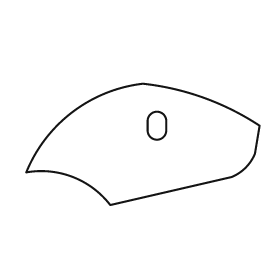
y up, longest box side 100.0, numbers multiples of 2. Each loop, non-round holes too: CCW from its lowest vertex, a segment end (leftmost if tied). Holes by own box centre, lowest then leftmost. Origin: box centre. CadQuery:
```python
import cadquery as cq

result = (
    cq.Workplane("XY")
    .moveTo(-14.0, -26.0)
    .lineTo(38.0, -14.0)
    .threePointArc((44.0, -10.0), (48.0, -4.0))
    .lineTo(50.0, 8.0)
    .threePointArc((26.0, 20.0), (0.0, 26.0))
    .threePointArc((-30.0, 14.0), (-50.0, -12.0))
    .threePointArc((-30.0, -14.0), (-14.0, -26.0))
    .close()
    .moveTo(2.0, 6.0)
    .threePointArc((6.0, 2.0), (10.0, 6.0))
    .lineTo(10.0, 10.0)
    .threePointArc((6.0, 14.0), (2.0, 10.0))
    .close()
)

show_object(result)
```